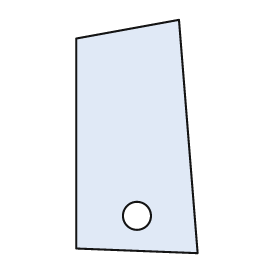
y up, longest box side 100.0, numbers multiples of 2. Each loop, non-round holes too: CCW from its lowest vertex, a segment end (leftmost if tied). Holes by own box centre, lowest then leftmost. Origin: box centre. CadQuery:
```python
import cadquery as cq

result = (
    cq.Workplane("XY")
    .moveTo(26.0, -50.0)
    .lineTo(18.0, 50.0)
    .lineTo(-26.0, 42.0)
    .lineTo(-26.0, -48.0)
    .close()
    .moveTo(0.0, -34.0)
    .circle(6.0)
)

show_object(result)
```